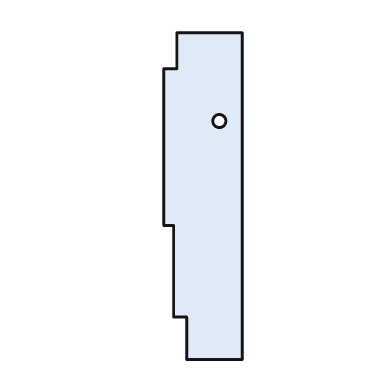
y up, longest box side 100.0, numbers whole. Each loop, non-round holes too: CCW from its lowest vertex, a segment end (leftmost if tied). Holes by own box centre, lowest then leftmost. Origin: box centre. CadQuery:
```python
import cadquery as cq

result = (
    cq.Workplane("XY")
    .moveTo(-5.0, -50.0)
    .lineTo(12.0, -50.0)
    .lineTo(12.0, 50.0)
    .lineTo(-8.0, 50.0)
    .lineTo(-8.0, 39.0)
    .lineTo(-12.0, 39.0)
    .lineTo(-12.0, -9.0)
    .lineTo(-9.0, -9.0)
    .lineTo(-9.0, -37.0)
    .lineTo(-5.0, -37.0)
    .close()
    .moveTo(5.0, 23.0)
    .circle(2.0)
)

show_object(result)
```